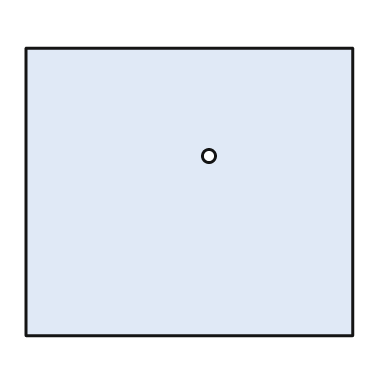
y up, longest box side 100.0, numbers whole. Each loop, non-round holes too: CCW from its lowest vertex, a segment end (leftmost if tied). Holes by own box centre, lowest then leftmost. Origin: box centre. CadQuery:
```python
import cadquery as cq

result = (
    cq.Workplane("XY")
    .moveTo(-50.0, -44.0)
    .lineTo(50.0, -44.0)
    .lineTo(50.0, 44.0)
    .lineTo(-50.0, 44.0)
    .close()
    .moveTo(6.0, 11.0)
    .circle(2.0)
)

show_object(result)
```